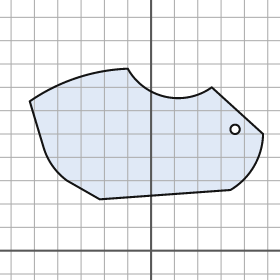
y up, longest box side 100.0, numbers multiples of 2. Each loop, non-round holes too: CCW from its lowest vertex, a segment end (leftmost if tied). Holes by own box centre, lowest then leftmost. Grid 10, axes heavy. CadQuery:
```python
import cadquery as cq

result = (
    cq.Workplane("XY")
    .moveTo(-22.0, 22.0)
    .lineTo(34.0, 26.0)
    .threePointArc((44.0, 36.0), (48.0, 50.0))
    .lineTo(26.0, 70.0)
    .threePointArc((6.0, 66.0), (-10.0, 78.0))
    .threePointArc((-32.0, 74.0), (-52.0, 64.0))
    .lineTo(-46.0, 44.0)
    .threePointArc((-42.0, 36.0), (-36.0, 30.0))
    .close()
    .moveTo(36.0, 52.0)
    .circle(2.0)
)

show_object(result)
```